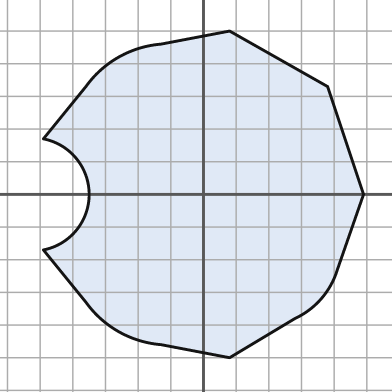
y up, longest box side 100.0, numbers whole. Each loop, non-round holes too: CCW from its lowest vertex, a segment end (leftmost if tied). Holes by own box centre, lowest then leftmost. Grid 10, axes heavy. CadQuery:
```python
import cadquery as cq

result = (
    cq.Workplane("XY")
    .moveTo(8.0, -50.0)
    .lineTo(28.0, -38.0)
    .threePointArc((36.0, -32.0), (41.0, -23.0))
    .lineTo(49.0, 0.0)
    .lineTo(38.0, 33.0)
    .lineTo(8.0, 50.0)
    .lineTo(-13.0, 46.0)
    .threePointArc((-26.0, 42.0), (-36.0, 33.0))
    .lineTo(-49.0, 17.0)
    .threePointArc((-35.0, 0.0), (-49.0, -17.0))
    .lineTo(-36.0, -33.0)
    .threePointArc((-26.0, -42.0), (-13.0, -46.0))
    .close()
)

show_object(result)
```